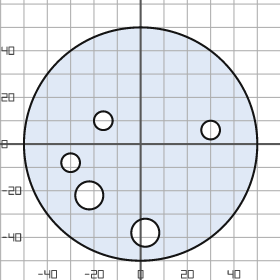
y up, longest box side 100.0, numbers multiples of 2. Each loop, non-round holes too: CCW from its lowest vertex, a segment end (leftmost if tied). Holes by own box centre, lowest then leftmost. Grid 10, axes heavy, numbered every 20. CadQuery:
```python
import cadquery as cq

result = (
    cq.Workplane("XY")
    .moveTo(0.0, 0.0)
    .circle(50.0)
    .moveTo(2.0, -38.0)
    .circle(6.0)
    .moveTo(-22.0, -22.0)
    .circle(6.0)
    .moveTo(-30.0, -8.0)
    .circle(4.0)
    .moveTo(30.0, 6.0)
    .circle(4.0)
    .moveTo(-16.0, 10.0)
    .circle(4.0)
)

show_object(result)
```